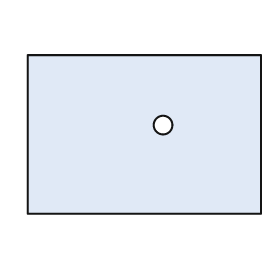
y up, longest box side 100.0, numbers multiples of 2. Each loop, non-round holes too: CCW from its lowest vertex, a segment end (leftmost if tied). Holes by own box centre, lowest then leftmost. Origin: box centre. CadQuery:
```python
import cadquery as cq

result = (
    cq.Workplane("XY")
    .moveTo(-50.0, -34.0)
    .lineTo(50.0, -34.0)
    .lineTo(50.0, 34.0)
    .lineTo(-50.0, 34.0)
    .close()
    .moveTo(8.0, 4.0)
    .circle(4.0)
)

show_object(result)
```